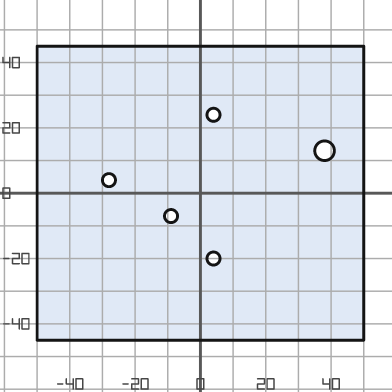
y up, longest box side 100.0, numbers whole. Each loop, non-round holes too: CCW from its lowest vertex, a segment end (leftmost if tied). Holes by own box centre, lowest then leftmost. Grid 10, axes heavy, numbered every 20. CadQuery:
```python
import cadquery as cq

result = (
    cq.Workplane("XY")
    .moveTo(-50.0, -45.0)
    .lineTo(50.0, -45.0)
    .lineTo(50.0, 45.0)
    .lineTo(-50.0, 45.0)
    .close()
    .moveTo(4.0, -20.0)
    .circle(2.0)
    .moveTo(-9.0, -7.0)
    .circle(2.0)
    .moveTo(-28.0, 4.0)
    .circle(2.0)
    .moveTo(38.0, 13.0)
    .circle(3.0)
    .moveTo(4.0, 24.0)
    .circle(2.0)
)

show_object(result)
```